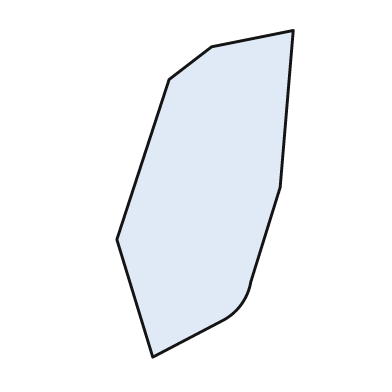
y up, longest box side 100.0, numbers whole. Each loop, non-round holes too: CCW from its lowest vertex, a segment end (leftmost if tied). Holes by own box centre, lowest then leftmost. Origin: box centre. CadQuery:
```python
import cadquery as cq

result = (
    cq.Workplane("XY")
    .moveTo(-16.0, -50.0)
    .lineTo(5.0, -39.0)
    .threePointArc((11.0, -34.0), (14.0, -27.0))
    .lineTo(23.0, 2.0)
    .lineTo(27.0, 50.0)
    .lineTo(2.0, 45.0)
    .lineTo(-11.0, 35.0)
    .lineTo(-27.0, -14.0)
    .close()
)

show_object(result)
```